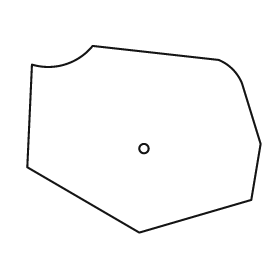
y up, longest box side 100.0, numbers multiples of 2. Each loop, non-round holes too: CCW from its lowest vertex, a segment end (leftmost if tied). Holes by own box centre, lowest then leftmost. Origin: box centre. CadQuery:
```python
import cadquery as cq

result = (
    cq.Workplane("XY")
    .moveTo(-2.0, -40.0)
    .lineTo(46.0, -26.0)
    .lineTo(50.0, -2.0)
    .lineTo(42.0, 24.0)
    .threePointArc((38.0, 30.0), (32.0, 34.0))
    .lineTo(-22.0, 40.0)
    .threePointArc((-34.0, 32.0), (-48.0, 32.0))
    .lineTo(-50.0, -12.0)
    .close()
    .moveTo(0.0, -4.0)
    .circle(2.0)
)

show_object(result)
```